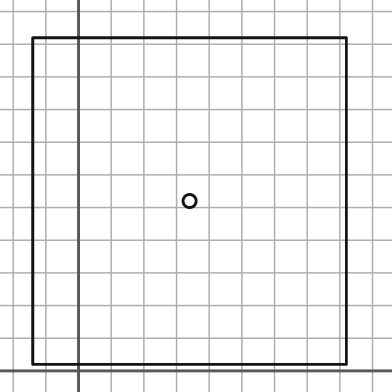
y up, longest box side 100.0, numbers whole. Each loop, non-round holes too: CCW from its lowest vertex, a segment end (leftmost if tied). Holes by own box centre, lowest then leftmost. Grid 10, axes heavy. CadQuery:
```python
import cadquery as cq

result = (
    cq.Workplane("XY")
    .moveTo(-14.0, 2.0)
    .lineTo(82.0, 2.0)
    .lineTo(82.0, 102.0)
    .lineTo(-14.0, 102.0)
    .close()
    .moveTo(34.0, 52.0)
    .circle(2.0)
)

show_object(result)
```